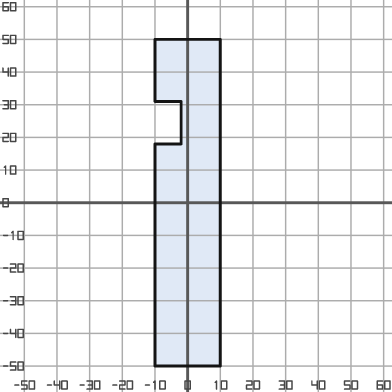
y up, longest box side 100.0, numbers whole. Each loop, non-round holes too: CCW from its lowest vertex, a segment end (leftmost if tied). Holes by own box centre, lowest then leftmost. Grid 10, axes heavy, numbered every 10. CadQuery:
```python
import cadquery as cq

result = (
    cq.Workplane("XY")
    .moveTo(-10.0, -50.0)
    .lineTo(10.0, -50.0)
    .lineTo(10.0, 50.0)
    .lineTo(-10.0, 50.0)
    .lineTo(-10.0, 31.0)
    .lineTo(-2.0, 31.0)
    .lineTo(-2.0, 18.0)
    .lineTo(-10.0, 18.0)
    .close()
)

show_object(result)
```